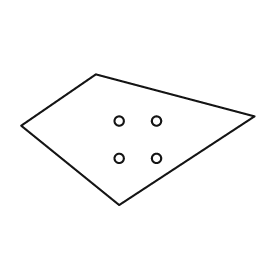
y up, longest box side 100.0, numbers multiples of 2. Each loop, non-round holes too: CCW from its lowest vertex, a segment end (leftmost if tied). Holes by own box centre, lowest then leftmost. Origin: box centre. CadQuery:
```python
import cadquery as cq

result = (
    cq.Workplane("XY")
    .moveTo(-8.0, -28.0)
    .lineTo(50.0, 10.0)
    .lineTo(-18.0, 28.0)
    .lineTo(-50.0, 6.0)
    .close()
    .moveTo(-8.0, -8.0)
    .circle(2.0)
    .moveTo(8.0, -8.0)
    .circle(2.0)
    .moveTo(-8.0, 8.0)
    .circle(2.0)
    .moveTo(8.0, 8.0)
    .circle(2.0)
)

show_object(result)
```